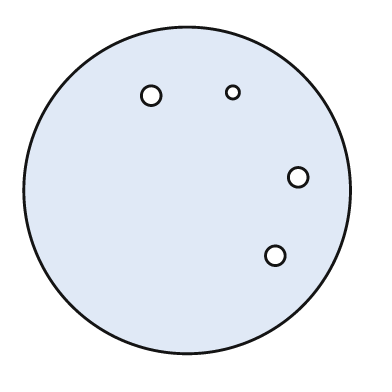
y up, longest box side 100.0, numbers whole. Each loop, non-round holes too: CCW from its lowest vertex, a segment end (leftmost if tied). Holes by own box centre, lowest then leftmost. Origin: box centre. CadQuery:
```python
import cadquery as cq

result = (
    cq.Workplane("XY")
    .moveTo(0.0, 0.0)
    .circle(50.0)
    .moveTo(27.0, -20.0)
    .circle(3.0)
    .moveTo(34.0, 4.0)
    .circle(3.0)
    .moveTo(-11.0, 29.0)
    .circle(3.0)
    .moveTo(14.0, 30.0)
    .circle(2.0)
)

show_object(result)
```